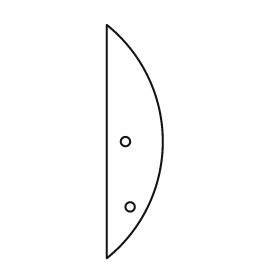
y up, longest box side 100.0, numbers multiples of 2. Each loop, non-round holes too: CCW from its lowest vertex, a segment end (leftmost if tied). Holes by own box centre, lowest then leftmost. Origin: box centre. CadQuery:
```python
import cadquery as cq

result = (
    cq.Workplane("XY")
    .moveTo(-12.0, -50.0)
    .threePointArc((12.0, 0.0), (-12.0, 50.0))
    .close()
    .moveTo(-2.0, -28.0)
    .circle(2.0)
    .moveTo(-4.0, 0.0)
    .circle(2.0)
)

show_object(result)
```